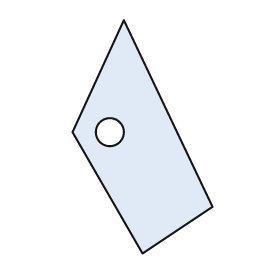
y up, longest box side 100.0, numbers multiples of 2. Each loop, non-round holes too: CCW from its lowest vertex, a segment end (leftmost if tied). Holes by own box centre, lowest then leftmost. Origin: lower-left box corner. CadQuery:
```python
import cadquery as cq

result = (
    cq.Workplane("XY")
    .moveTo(30.0, 0.0)
    .lineTo(60.0, 20.0)
    .lineTo(22.0, 100.0)
    .lineTo(0.0, 52.0)
    .close()
    .moveTo(16.0, 52.0)
    .circle(6.0)
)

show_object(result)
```